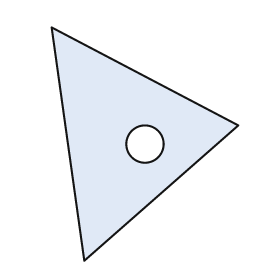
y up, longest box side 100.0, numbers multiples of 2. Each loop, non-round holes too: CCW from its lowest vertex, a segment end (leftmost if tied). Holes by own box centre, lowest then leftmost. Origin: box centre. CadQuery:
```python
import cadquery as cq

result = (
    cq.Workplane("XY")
    .moveTo(-26.0, -50.0)
    .lineTo(40.0, 8.0)
    .lineTo(-40.0, 50.0)
    .close()
    .moveTo(0.0, 0.0)
    .circle(8.0)
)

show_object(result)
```